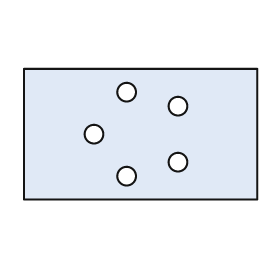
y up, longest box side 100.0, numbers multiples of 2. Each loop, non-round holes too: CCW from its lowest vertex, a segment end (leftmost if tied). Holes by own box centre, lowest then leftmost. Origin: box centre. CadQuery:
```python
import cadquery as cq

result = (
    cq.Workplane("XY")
    .moveTo(-50.0, -28.0)
    .lineTo(50.0, -28.0)
    .lineTo(50.0, 28.0)
    .lineTo(-50.0, 28.0)
    .close()
    .moveTo(-6.0, -18.0)
    .circle(4.0)
    .moveTo(16.0, -12.0)
    .circle(4.0)
    .moveTo(-20.0, 0.0)
    .circle(4.0)
    .moveTo(16.0, 12.0)
    .circle(4.0)
    .moveTo(-6.0, 18.0)
    .circle(4.0)
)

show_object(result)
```